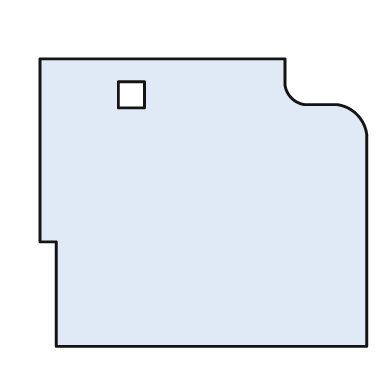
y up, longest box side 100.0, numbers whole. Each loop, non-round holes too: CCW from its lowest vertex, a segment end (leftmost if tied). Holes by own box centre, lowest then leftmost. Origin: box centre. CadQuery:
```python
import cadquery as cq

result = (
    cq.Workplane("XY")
    .moveTo(-45.0, -44.0)
    .lineTo(50.0, -44.0)
    .lineTo(50.0, 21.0)
    .threePointArc((47.0, 27.0), (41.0, 30.0))
    .lineTo(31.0, 30.0)
    .threePointArc((27.0, 32.0), (25.0, 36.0))
    .lineTo(25.0, 44.0)
    .lineTo(-50.0, 44.0)
    .lineTo(-50.0, -12.0)
    .lineTo(-45.0, -12.0)
    .close()
    .moveTo(-26.0, 29.0)
    .lineTo(-18.0, 29.0)
    .lineTo(-18.0, 37.0)
    .lineTo(-26.0, 37.0)
    .close()
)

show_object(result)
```